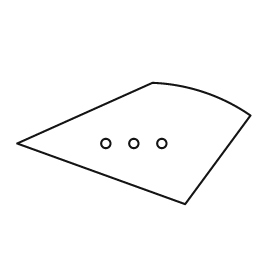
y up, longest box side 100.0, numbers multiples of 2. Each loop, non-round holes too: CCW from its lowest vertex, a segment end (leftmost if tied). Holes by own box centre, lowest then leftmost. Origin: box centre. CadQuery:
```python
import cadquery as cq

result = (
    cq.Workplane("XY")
    .moveTo(22.0, -26.0)
    .lineTo(50.0, 12.0)
    .threePointArc((30.0, 22.0), (8.0, 26.0))
    .lineTo(-50.0, 0.0)
    .close()
    .moveTo(-12.0, 0.0)
    .circle(2.0)
    .moveTo(0.0, 0.0)
    .circle(2.0)
    .moveTo(12.0, 0.0)
    .circle(2.0)
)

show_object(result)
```